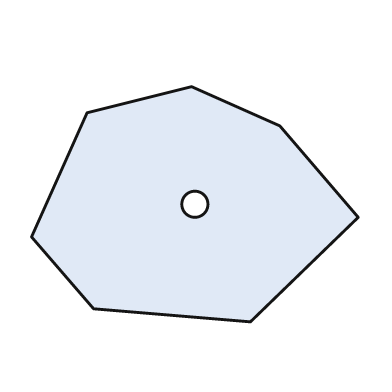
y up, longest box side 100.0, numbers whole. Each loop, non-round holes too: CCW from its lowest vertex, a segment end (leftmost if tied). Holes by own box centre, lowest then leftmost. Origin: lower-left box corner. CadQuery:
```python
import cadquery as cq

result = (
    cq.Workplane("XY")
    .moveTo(67.0, 0.0)
    .lineTo(100.0, 32.0)
    .lineTo(76.0, 60.0)
    .lineTo(49.0, 72.0)
    .lineTo(17.0, 64.0)
    .lineTo(0.0, 26.0)
    .lineTo(19.0, 4.0)
    .close()
    .moveTo(50.0, 36.0)
    .circle(4.0)
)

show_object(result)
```